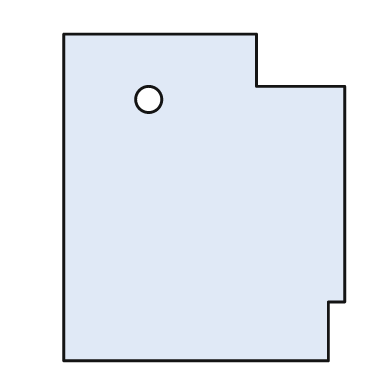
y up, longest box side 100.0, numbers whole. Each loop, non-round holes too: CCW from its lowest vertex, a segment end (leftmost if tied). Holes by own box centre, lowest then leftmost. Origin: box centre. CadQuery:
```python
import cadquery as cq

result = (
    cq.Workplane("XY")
    .moveTo(-43.0, -50.0)
    .lineTo(38.0, -50.0)
    .lineTo(38.0, -32.0)
    .lineTo(43.0, -32.0)
    .lineTo(43.0, 34.0)
    .lineTo(16.0, 34.0)
    .lineTo(16.0, 50.0)
    .lineTo(-43.0, 50.0)
    .close()
    .moveTo(-17.0, 30.0)
    .circle(4.0)
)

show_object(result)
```